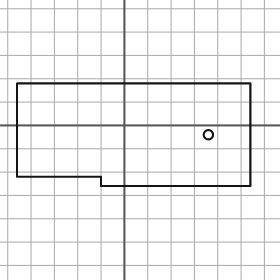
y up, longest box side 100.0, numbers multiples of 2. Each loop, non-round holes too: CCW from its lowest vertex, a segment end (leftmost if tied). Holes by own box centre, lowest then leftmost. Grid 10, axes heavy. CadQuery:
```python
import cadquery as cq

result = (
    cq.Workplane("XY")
    .moveTo(-10.0, -26.0)
    .lineTo(54.0, -26.0)
    .lineTo(54.0, 18.0)
    .lineTo(-46.0, 18.0)
    .lineTo(-46.0, -22.0)
    .lineTo(-10.0, -22.0)
    .close()
    .moveTo(36.0, -4.0)
    .circle(2.0)
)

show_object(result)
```